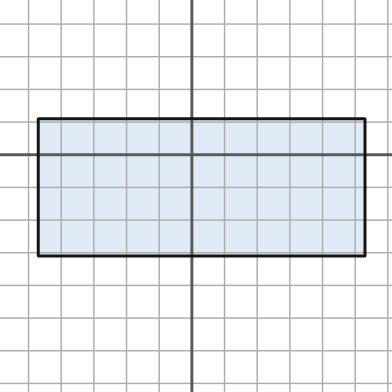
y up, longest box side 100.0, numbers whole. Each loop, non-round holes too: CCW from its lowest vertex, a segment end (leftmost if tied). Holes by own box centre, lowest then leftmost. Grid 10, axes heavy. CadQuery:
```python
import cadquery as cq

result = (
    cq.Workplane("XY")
    .moveTo(-47.0, -31.0)
    .lineTo(53.0, -31.0)
    .lineTo(53.0, 11.0)
    .lineTo(-47.0, 11.0)
    .close()
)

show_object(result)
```